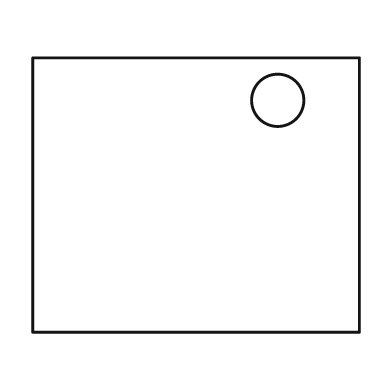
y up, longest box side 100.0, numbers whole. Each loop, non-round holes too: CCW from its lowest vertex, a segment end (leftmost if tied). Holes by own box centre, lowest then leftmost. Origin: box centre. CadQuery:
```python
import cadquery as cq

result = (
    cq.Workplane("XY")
    .moveTo(-50.0, -42.0)
    .lineTo(50.0, -42.0)
    .lineTo(50.0, 42.0)
    .lineTo(-50.0, 42.0)
    .close()
    .moveTo(25.0, 29.0)
    .circle(8.0)
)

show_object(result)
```